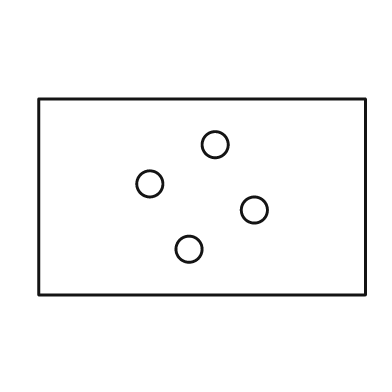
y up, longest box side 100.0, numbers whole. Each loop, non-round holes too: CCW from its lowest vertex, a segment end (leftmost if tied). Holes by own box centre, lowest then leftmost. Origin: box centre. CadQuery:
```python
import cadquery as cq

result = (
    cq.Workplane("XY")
    .moveTo(-50.0, -30.0)
    .lineTo(50.0, -30.0)
    .lineTo(50.0, 30.0)
    .lineTo(-50.0, 30.0)
    .close()
    .moveTo(-4.0, -16.0)
    .circle(4.0)
    .moveTo(16.0, -4.0)
    .circle(4.0)
    .moveTo(-16.0, 4.0)
    .circle(4.0)
    .moveTo(4.0, 16.0)
    .circle(4.0)
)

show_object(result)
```